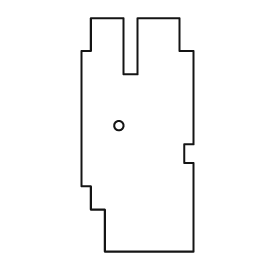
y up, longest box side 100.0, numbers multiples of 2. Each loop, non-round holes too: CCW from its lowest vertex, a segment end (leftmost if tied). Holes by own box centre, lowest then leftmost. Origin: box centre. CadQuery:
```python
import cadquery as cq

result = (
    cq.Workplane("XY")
    .moveTo(-14.0, -50.0)
    .lineTo(24.0, -50.0)
    .lineTo(24.0, -12.0)
    .lineTo(20.0, -12.0)
    .lineTo(20.0, -4.0)
    .lineTo(24.0, -4.0)
    .lineTo(24.0, 36.0)
    .lineTo(18.0, 36.0)
    .lineTo(18.0, 50.0)
    .lineTo(0.0, 50.0)
    .lineTo(0.0, 26.0)
    .lineTo(-6.0, 26.0)
    .lineTo(-6.0, 50.0)
    .lineTo(-20.0, 50.0)
    .lineTo(-20.0, 36.0)
    .lineTo(-24.0, 36.0)
    .lineTo(-24.0, -22.0)
    .lineTo(-20.0, -22.0)
    .lineTo(-20.0, -32.0)
    .lineTo(-14.0, -32.0)
    .close()
    .moveTo(-8.0, 4.0)
    .circle(2.0)
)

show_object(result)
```